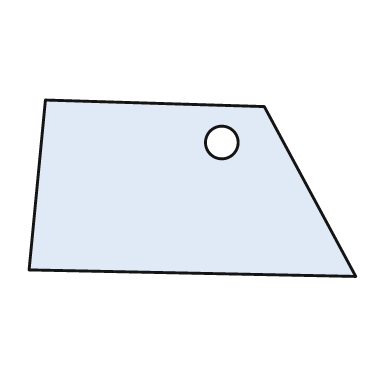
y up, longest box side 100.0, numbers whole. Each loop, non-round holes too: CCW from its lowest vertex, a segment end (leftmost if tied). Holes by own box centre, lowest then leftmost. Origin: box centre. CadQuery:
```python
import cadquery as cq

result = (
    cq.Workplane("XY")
    .moveTo(50.0, -27.0)
    .lineTo(22.0, 25.0)
    .lineTo(-45.0, 27.0)
    .lineTo(-50.0, -25.0)
    .close()
    .moveTo(9.0, 14.0)
    .circle(5.0)
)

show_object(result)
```